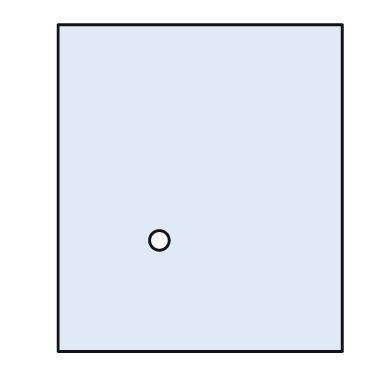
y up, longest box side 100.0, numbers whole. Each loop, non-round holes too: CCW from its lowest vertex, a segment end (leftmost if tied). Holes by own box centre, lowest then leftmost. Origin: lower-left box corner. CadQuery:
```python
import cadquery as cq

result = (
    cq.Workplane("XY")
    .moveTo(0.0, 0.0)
    .lineTo(87.0, 0.0)
    .lineTo(87.0, 100.0)
    .lineTo(0.0, 100.0)
    .close()
    .moveTo(31.0, 34.0)
    .circle(3.0)
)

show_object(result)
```